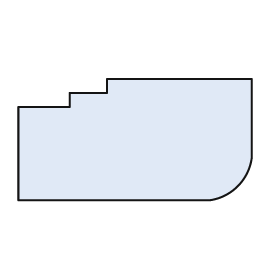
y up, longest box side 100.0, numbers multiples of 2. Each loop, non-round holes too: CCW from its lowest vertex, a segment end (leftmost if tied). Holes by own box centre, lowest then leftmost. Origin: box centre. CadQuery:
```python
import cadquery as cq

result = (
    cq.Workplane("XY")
    .moveTo(-50.0, -26.0)
    .lineTo(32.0, -26.0)
    .threePointArc((44.0, -20.0), (50.0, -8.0))
    .lineTo(50.0, 26.0)
    .lineTo(-12.0, 26.0)
    .lineTo(-12.0, 20.0)
    .lineTo(-28.0, 20.0)
    .lineTo(-28.0, 14.0)
    .lineTo(-50.0, 14.0)
    .close()
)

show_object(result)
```